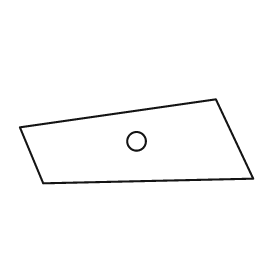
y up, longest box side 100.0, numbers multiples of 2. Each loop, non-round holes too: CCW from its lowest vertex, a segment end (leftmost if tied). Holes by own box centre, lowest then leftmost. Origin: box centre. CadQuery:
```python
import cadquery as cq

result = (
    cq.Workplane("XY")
    .moveTo(-40.0, -18.0)
    .lineTo(50.0, -16.0)
    .lineTo(34.0, 18.0)
    .lineTo(-50.0, 6.0)
    .close()
    .moveTo(0.0, 0.0)
    .circle(4.0)
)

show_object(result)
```